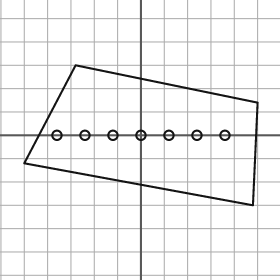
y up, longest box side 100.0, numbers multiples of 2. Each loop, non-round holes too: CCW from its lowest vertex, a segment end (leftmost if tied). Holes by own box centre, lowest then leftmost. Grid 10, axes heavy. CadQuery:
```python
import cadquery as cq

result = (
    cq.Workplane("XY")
    .moveTo(48.0, -30.0)
    .lineTo(50.0, 14.0)
    .lineTo(-28.0, 30.0)
    .lineTo(-50.0, -12.0)
    .close()
    .moveTo(-36.0, 0.0)
    .circle(2.0)
    .moveTo(-24.0, 0.0)
    .circle(2.0)
    .moveTo(-12.0, 0.0)
    .circle(2.0)
    .moveTo(0.0, 0.0)
    .circle(2.0)
    .moveTo(12.0, 0.0)
    .circle(2.0)
    .moveTo(24.0, 0.0)
    .circle(2.0)
    .moveTo(36.0, 0.0)
    .circle(2.0)
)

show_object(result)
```